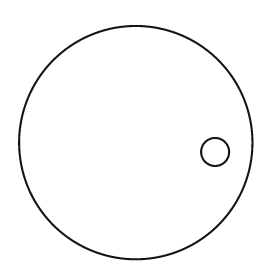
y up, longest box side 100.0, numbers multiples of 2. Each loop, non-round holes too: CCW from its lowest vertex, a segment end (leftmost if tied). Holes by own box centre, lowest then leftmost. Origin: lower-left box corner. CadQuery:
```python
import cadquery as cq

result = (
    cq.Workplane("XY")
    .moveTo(50.0, 50.0)
    .circle(50.0)
    .moveTo(84.0, 46.0)
    .circle(6.0)
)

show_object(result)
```